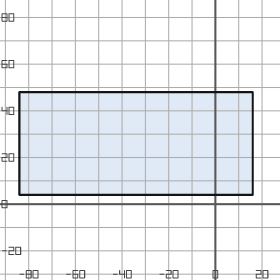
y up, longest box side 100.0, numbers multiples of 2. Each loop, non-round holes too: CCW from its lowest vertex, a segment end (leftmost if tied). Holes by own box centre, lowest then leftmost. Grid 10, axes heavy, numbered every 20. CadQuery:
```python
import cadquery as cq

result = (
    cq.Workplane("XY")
    .moveTo(-84.0, 4.0)
    .lineTo(16.0, 4.0)
    .lineTo(16.0, 48.0)
    .lineTo(-84.0, 48.0)
    .close()
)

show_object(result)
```